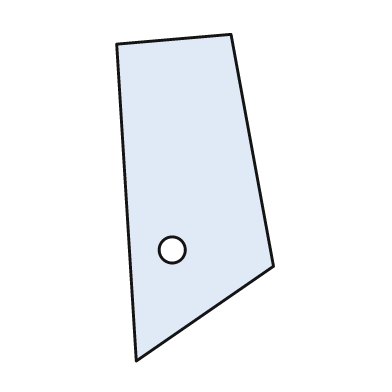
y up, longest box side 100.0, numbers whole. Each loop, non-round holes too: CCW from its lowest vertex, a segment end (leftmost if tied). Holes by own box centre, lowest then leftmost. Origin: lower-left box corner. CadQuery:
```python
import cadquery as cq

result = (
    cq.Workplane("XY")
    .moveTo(6.0, 0.0)
    .lineTo(48.0, 29.0)
    .lineTo(35.0, 100.0)
    .lineTo(0.0, 97.0)
    .close()
    .moveTo(17.0, 34.0)
    .circle(4.0)
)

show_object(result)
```